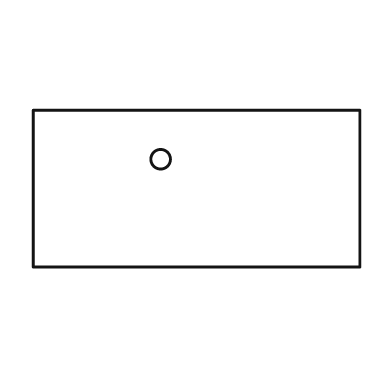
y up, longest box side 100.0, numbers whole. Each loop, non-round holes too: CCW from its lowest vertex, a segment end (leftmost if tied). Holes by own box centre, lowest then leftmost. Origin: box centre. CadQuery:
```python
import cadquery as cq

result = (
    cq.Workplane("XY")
    .moveTo(-50.0, -24.0)
    .lineTo(50.0, -24.0)
    .lineTo(50.0, 24.0)
    .lineTo(-50.0, 24.0)
    .close()
    .moveTo(-11.0, 9.0)
    .circle(3.0)
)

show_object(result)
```